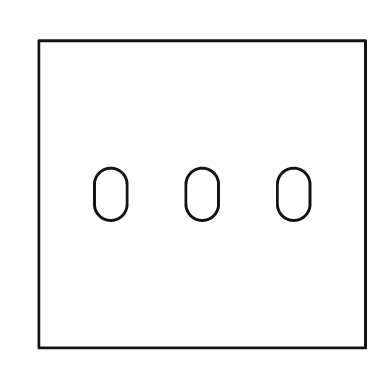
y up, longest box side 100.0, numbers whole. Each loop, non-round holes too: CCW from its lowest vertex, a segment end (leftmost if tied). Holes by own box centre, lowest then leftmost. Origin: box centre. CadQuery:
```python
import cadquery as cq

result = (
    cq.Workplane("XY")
    .moveTo(-50.0, -47.0)
    .lineTo(50.0, -47.0)
    .lineTo(50.0, 47.0)
    .lineTo(-50.0, 47.0)
    .close()
    .moveTo(-33.0, -3.0)
    .threePointArc((-28.0, -8.0), (-23.0, -3.0))
    .lineTo(-23.0, 3.0)
    .threePointArc((-28.0, 8.0), (-33.0, 3.0))
    .close()
    .moveTo(-5.0, -3.0)
    .threePointArc((0.0, -8.0), (5.0, -3.0))
    .lineTo(5.0, 3.0)
    .threePointArc((0.0, 8.0), (-5.0, 3.0))
    .close()
    .moveTo(23.0, -3.0)
    .threePointArc((28.0, -8.0), (33.0, -3.0))
    .lineTo(33.0, 3.0)
    .threePointArc((28.0, 8.0), (23.0, 3.0))
    .close()
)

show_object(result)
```